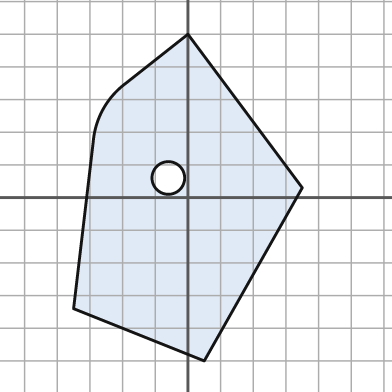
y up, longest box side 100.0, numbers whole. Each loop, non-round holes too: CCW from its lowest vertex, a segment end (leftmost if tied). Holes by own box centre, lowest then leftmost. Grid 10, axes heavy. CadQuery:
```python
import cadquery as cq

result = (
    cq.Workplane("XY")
    .moveTo(5.0, -50.0)
    .lineTo(35.0, 3.0)
    .lineTo(0.0, 50.0)
    .lineTo(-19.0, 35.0)
    .threePointArc((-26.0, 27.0), (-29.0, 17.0))
    .lineTo(-35.0, -34.0)
    .close()
    .moveTo(-6.0, 6.0)
    .circle(5.0)
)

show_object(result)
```